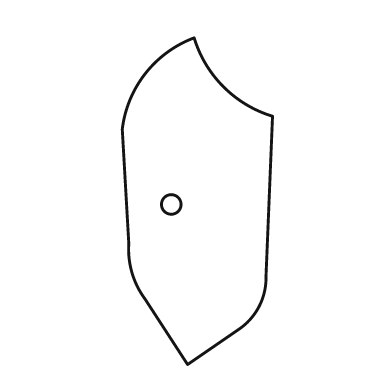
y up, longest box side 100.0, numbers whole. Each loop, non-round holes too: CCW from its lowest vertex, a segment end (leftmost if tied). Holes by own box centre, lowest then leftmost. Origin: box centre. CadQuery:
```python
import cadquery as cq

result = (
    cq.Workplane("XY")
    .moveTo(-3.0, -50.0)
    .lineTo(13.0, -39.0)
    .threePointArc((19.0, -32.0), (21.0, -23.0))
    .lineTo(23.0, 26.0)
    .threePointArc((8.0, 35.0), (-1.0, 50.0))
    .threePointArc((-16.0, 39.0), (-23.0, 22.0))
    .lineTo(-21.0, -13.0)
    .threePointArc((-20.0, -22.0), (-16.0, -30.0))
    .close()
    .moveTo(-8.0, -1.0)
    .circle(3.0)
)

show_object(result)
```